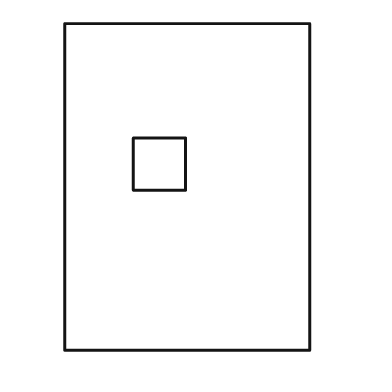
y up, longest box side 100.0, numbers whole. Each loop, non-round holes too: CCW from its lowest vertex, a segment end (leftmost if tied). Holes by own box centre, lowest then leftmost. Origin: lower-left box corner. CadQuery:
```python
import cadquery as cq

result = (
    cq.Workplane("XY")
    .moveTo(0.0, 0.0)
    .lineTo(75.0, 0.0)
    .lineTo(75.0, 100.0)
    .lineTo(0.0, 100.0)
    .close()
    .moveTo(21.0, 49.0)
    .lineTo(37.0, 49.0)
    .lineTo(37.0, 65.0)
    .lineTo(21.0, 65.0)
    .close()
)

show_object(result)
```